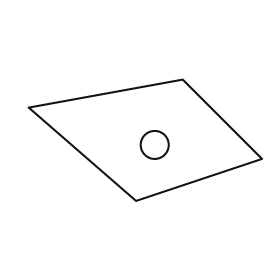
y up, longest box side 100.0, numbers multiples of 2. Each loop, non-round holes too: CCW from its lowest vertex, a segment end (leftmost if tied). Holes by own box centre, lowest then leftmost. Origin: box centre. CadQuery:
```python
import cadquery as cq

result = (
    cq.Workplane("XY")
    .moveTo(-4.0, -26.0)
    .lineTo(50.0, -8.0)
    .lineTo(16.0, 26.0)
    .lineTo(-50.0, 14.0)
    .close()
    .moveTo(4.0, -2.0)
    .circle(6.0)
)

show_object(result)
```